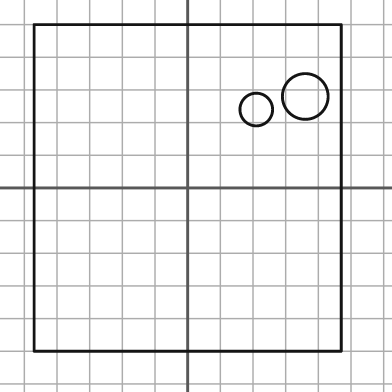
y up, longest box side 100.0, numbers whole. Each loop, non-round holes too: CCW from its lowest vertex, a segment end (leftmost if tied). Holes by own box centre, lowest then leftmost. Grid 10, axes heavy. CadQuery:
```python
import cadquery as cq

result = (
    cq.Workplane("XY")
    .moveTo(-47.0, -50.0)
    .lineTo(47.0, -50.0)
    .lineTo(47.0, 50.0)
    .lineTo(-47.0, 50.0)
    .close()
    .moveTo(21.0, 24.0)
    .circle(5.0)
    .moveTo(36.0, 28.0)
    .circle(7.0)
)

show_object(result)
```